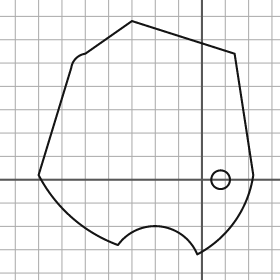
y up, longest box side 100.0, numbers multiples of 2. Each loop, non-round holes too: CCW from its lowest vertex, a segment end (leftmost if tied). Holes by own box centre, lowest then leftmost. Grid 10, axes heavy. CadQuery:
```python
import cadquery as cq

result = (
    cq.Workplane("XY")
    .moveTo(-2.0, -32.0)
    .threePointArc((14.0, -18.0), (22.0, 2.0))
    .lineTo(14.0, 54.0)
    .lineTo(-30.0, 68.0)
    .lineTo(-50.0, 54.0)
    .threePointArc((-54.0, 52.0), (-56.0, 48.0))
    .lineTo(-70.0, 2.0)
    .threePointArc((-56.0, -16.0), (-36.0, -28.0))
    .threePointArc((-18.0, -20.0), (-2.0, -32.0))
    .close()
    .moveTo(8.0, 0.0)
    .circle(4.0)
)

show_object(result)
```